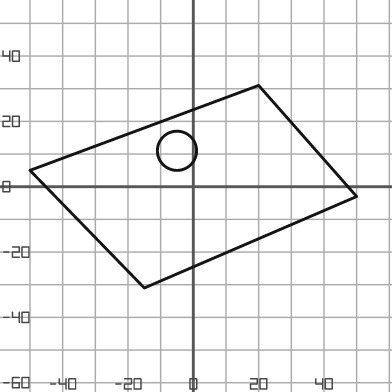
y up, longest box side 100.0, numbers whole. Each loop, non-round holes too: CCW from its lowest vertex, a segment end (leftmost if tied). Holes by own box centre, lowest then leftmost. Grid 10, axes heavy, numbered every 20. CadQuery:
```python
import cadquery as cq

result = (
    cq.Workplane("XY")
    .moveTo(-15.0, -31.0)
    .lineTo(50.0, -3.0)
    .lineTo(20.0, 31.0)
    .lineTo(-50.0, 5.0)
    .close()
    .moveTo(-5.0, 11.0)
    .circle(6.0)
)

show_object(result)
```